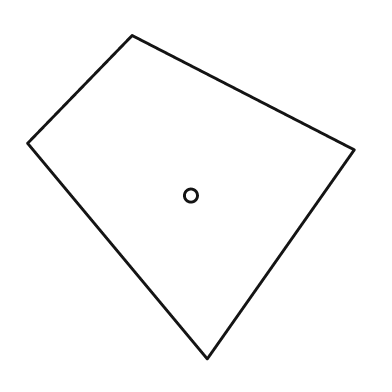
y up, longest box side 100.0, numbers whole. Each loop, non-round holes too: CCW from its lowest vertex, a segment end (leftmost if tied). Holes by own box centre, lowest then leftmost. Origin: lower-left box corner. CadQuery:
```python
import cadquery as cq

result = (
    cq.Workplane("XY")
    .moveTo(55.0, 0.0)
    .lineTo(100.0, 64.0)
    .lineTo(32.0, 99.0)
    .lineTo(0.0, 66.0)
    .close()
    .moveTo(50.0, 50.0)
    .circle(2.0)
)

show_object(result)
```